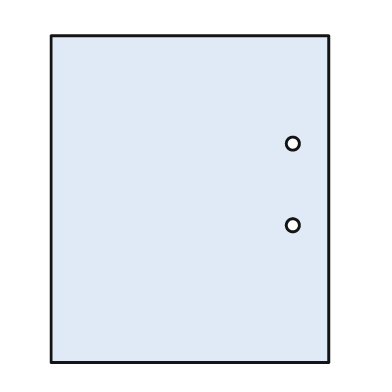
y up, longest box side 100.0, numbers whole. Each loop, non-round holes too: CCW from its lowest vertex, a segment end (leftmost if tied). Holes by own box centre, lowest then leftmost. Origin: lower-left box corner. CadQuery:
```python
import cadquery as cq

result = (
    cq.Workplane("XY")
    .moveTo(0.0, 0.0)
    .lineTo(85.0, 0.0)
    .lineTo(85.0, 100.0)
    .lineTo(0.0, 100.0)
    .close()
    .moveTo(74.0, 42.0)
    .circle(2.0)
    .moveTo(74.0, 67.0)
    .circle(2.0)
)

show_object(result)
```